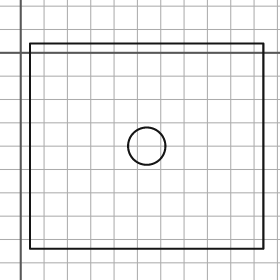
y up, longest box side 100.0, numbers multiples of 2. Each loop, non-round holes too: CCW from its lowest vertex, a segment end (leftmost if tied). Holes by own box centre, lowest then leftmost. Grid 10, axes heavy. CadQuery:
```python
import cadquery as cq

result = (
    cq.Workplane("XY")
    .moveTo(4.0, -84.0)
    .lineTo(104.0, -84.0)
    .lineTo(104.0, 4.0)
    .lineTo(4.0, 4.0)
    .close()
    .moveTo(54.0, -40.0)
    .circle(8.0)
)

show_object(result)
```